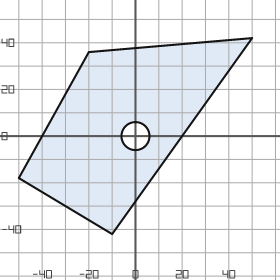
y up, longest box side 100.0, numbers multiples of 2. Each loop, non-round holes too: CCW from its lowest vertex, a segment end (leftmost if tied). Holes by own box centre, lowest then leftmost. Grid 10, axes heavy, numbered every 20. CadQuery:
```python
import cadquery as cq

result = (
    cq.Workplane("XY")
    .moveTo(-10.0, -42.0)
    .lineTo(50.0, 42.0)
    .lineTo(-20.0, 36.0)
    .lineTo(-50.0, -18.0)
    .close()
    .moveTo(0.0, 0.0)
    .circle(6.0)
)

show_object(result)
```